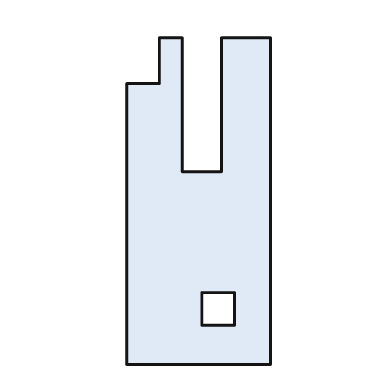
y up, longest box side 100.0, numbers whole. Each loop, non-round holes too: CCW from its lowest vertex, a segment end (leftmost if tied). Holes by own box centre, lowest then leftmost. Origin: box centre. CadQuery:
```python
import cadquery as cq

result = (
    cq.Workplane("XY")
    .moveTo(-22.0, -50.0)
    .lineTo(22.0, -50.0)
    .lineTo(22.0, 50.0)
    .lineTo(7.0, 50.0)
    .lineTo(7.0, 9.0)
    .lineTo(-5.0, 9.0)
    .lineTo(-5.0, 50.0)
    .lineTo(-12.0, 50.0)
    .lineTo(-12.0, 36.0)
    .lineTo(-22.0, 36.0)
    .close()
    .moveTo(1.0, -38.0)
    .lineTo(11.0, -38.0)
    .lineTo(11.0, -28.0)
    .lineTo(1.0, -28.0)
    .close()
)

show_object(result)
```